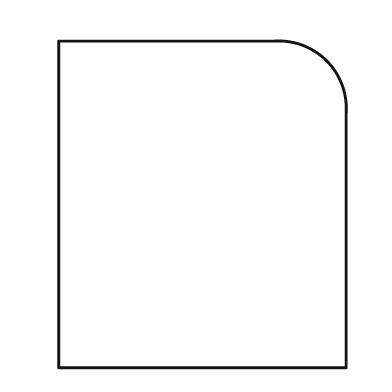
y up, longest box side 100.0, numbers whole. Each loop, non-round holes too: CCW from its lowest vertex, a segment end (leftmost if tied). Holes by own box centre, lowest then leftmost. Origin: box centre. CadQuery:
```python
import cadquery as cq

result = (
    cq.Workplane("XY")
    .moveTo(-44.0, -50.0)
    .lineTo(44.0, -50.0)
    .lineTo(44.0, 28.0)
    .threePointArc((38.0, 44.0), (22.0, 50.0))
    .lineTo(-44.0, 50.0)
    .close()
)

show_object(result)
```